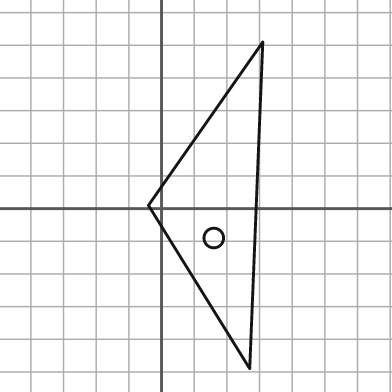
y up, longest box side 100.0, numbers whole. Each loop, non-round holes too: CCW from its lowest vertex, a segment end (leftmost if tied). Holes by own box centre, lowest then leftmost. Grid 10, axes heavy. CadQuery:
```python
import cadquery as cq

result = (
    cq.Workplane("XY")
    .moveTo(27.0, -49.0)
    .lineTo(31.0, 51.0)
    .lineTo(-4.0, 1.0)
    .close()
    .moveTo(16.0, -9.0)
    .circle(3.0)
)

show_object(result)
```